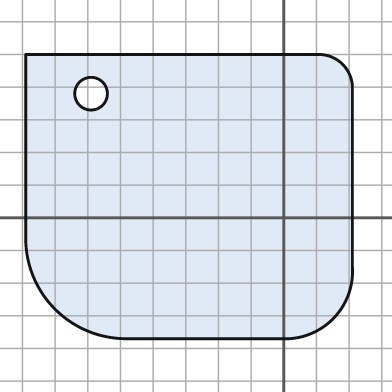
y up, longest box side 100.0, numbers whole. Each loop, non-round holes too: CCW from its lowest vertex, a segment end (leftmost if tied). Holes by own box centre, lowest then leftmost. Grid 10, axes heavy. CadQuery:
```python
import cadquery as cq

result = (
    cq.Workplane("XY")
    .moveTo(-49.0, -37.0)
    .lineTo(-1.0, -37.0)
    .threePointArc((15.0, -31.0), (21.0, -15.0))
    .lineTo(21.0, 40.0)
    .threePointArc((18.0, 47.0), (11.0, 50.0))
    .lineTo(-79.0, 50.0)
    .lineTo(-79.0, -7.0)
    .threePointArc((-70.0, -28.0), (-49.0, -37.0))
    .close()
    .moveTo(-59.0, 38.0)
    .circle(5.0)
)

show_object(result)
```